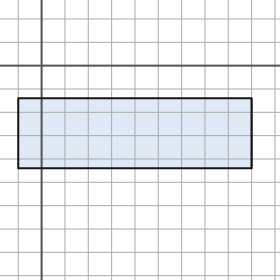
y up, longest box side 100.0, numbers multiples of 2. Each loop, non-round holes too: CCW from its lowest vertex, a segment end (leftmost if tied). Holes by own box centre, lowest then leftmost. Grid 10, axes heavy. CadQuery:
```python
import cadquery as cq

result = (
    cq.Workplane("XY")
    .moveTo(-10.0, -44.0)
    .lineTo(90.0, -44.0)
    .lineTo(90.0, -14.0)
    .lineTo(-10.0, -14.0)
    .close()
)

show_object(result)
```